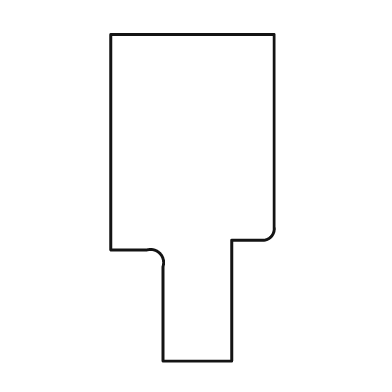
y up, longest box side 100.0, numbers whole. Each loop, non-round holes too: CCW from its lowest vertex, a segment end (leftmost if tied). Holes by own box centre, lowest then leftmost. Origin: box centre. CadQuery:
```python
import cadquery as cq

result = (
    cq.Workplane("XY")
    .moveTo(-9.0, -50.0)
    .lineTo(12.0, -50.0)
    .lineTo(12.0, -13.0)
    .lineTo(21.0, -13.0)
    .threePointArc((24.0, -12.0), (25.0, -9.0))
    .lineTo(25.0, 50.0)
    .lineTo(-25.0, 50.0)
    .lineTo(-25.0, -16.0)
    .lineTo(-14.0, -16.0)
    .threePointArc((-10.0, -17.0), (-9.0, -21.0))
    .close()
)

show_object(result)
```